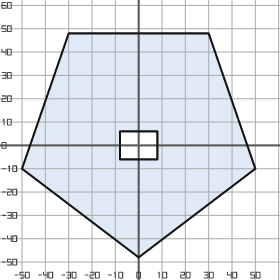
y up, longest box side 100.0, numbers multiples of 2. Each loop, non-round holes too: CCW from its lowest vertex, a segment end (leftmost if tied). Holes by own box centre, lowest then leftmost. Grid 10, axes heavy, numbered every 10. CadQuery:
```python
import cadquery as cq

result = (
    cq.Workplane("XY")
    .moveTo(0.0, -48.0)
    .lineTo(50.0, -10.0)
    .lineTo(30.0, 48.0)
    .lineTo(-30.0, 48.0)
    .lineTo(-50.0, -10.0)
    .close()
    .moveTo(-8.0, -6.0)
    .lineTo(8.0, -6.0)
    .lineTo(8.0, 6.0)
    .lineTo(-8.0, 6.0)
    .close()
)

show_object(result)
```